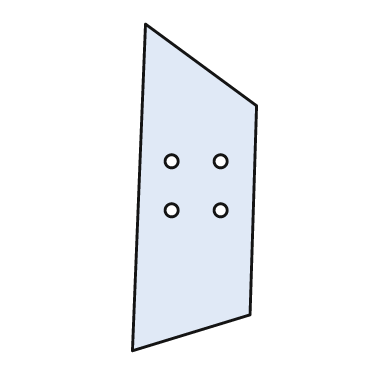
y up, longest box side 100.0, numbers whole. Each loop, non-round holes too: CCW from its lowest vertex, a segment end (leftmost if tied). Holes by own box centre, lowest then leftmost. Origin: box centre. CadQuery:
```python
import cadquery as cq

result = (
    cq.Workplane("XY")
    .moveTo(-19.0, -50.0)
    .lineTo(17.0, -39.0)
    .lineTo(19.0, 25.0)
    .lineTo(-15.0, 50.0)
    .close()
    .moveTo(-7.0, -7.0)
    .circle(2.0)
    .moveTo(8.0, -7.0)
    .circle(2.0)
    .moveTo(-7.0, 8.0)
    .circle(2.0)
    .moveTo(8.0, 8.0)
    .circle(2.0)
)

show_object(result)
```